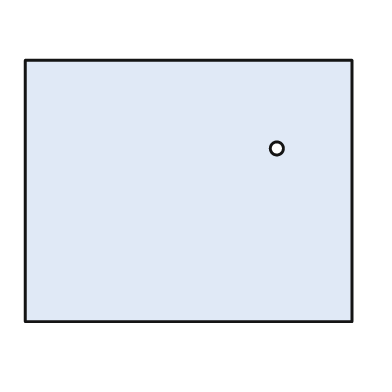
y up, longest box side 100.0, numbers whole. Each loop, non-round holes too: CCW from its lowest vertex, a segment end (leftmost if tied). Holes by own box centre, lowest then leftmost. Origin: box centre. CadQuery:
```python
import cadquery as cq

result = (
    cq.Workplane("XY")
    .moveTo(-50.0, -40.0)
    .lineTo(50.0, -40.0)
    .lineTo(50.0, 40.0)
    .lineTo(-50.0, 40.0)
    .close()
    .moveTo(27.0, 13.0)
    .circle(2.0)
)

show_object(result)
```